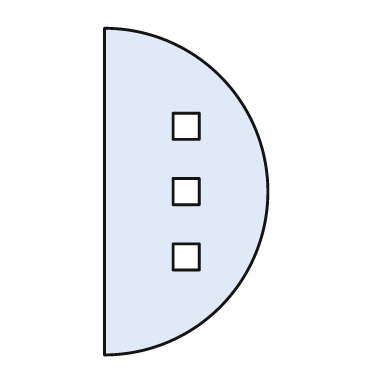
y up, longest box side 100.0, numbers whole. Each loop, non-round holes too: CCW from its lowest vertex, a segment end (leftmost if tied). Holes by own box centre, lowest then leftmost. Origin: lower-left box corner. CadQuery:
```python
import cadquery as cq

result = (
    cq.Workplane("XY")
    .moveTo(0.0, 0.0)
    .threePointArc((50.0, 50.0), (0.0, 100.0))
    .close()
    .moveTo(21.0, 26.0)
    .lineTo(29.0, 26.0)
    .lineTo(29.0, 34.0)
    .lineTo(21.0, 34.0)
    .close()
    .moveTo(21.0, 46.0)
    .lineTo(29.0, 46.0)
    .lineTo(29.0, 54.0)
    .lineTo(21.0, 54.0)
    .close()
    .moveTo(21.0, 66.0)
    .lineTo(29.0, 66.0)
    .lineTo(29.0, 74.0)
    .lineTo(21.0, 74.0)
    .close()
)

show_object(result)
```